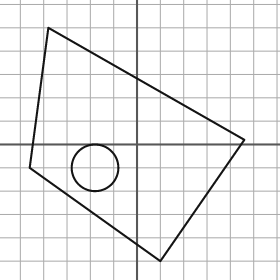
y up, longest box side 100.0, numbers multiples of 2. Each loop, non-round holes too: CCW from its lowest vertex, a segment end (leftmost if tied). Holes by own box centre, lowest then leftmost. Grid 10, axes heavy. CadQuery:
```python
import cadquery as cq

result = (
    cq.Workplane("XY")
    .moveTo(10.0, -50.0)
    .lineTo(46.0, 2.0)
    .lineTo(-38.0, 50.0)
    .lineTo(-46.0, -10.0)
    .close()
    .moveTo(-18.0, -10.0)
    .circle(10.0)
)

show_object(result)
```